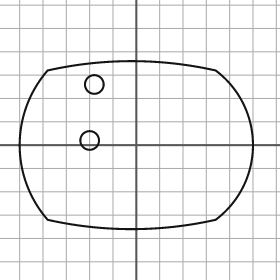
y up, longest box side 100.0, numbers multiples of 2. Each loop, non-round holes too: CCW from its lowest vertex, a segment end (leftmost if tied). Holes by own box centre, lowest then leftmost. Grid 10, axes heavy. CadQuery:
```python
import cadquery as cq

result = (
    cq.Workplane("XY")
    .moveTo(-38.0, -32.0)
    .threePointArc((-2.0, -36.0), (34.0, -32.0))
    .threePointArc((50.0, 0.0), (34.0, 32.0))
    .threePointArc((-2.0, 36.0), (-38.0, 32.0))
    .threePointArc((-50.0, 0.0), (-38.0, -32.0))
    .close()
    .moveTo(-20.0, 2.0)
    .circle(4.0)
    .moveTo(-18.0, 26.0)
    .circle(4.0)
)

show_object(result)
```